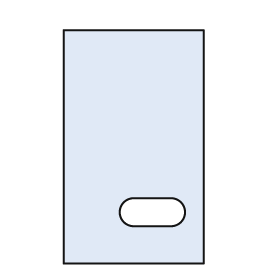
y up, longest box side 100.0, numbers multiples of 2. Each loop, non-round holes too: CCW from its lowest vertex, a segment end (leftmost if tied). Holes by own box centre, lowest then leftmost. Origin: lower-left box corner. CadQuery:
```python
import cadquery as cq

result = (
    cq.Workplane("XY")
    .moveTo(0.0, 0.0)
    .lineTo(60.0, 0.0)
    .lineTo(60.0, 100.0)
    .lineTo(0.0, 100.0)
    .close()
    .moveTo(30.0, 16.0)
    .lineTo(46.0, 16.0)
    .threePointArc((52.0, 22.0), (46.0, 28.0))
    .lineTo(30.0, 28.0)
    .threePointArc((24.0, 22.0), (30.0, 16.0))
    .close()
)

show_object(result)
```